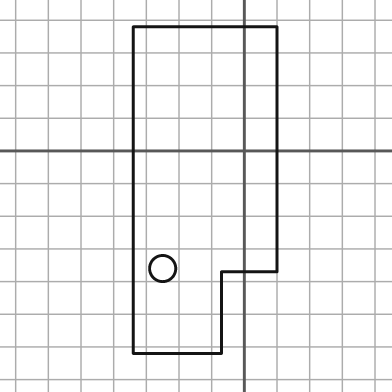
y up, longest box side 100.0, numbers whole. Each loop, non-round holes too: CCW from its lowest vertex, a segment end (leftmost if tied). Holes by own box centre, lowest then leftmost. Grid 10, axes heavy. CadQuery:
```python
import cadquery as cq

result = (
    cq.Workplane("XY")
    .moveTo(-34.0, -62.0)
    .lineTo(-7.0, -62.0)
    .lineTo(-7.0, -37.0)
    .lineTo(10.0, -37.0)
    .lineTo(10.0, 38.0)
    .lineTo(-34.0, 38.0)
    .close()
    .moveTo(-25.0, -36.0)
    .circle(4.0)
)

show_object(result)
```